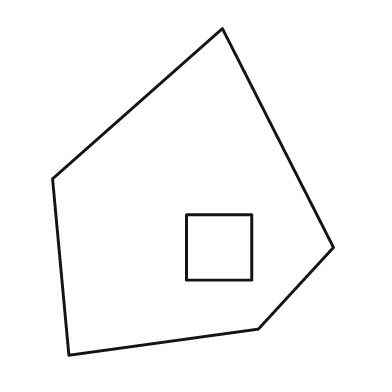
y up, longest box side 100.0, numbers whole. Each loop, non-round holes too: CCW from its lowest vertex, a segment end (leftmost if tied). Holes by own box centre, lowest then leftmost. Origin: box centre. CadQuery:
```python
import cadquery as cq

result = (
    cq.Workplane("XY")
    .moveTo(-38.0, -50.0)
    .lineTo(20.0, -42.0)
    .lineTo(43.0, -17.0)
    .lineTo(9.0, 50.0)
    .lineTo(-43.0, 4.0)
    .close()
    .moveTo(-2.0, -27.0)
    .lineTo(18.0, -27.0)
    .lineTo(18.0, -7.0)
    .lineTo(-2.0, -7.0)
    .close()
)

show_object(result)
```